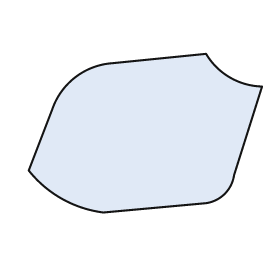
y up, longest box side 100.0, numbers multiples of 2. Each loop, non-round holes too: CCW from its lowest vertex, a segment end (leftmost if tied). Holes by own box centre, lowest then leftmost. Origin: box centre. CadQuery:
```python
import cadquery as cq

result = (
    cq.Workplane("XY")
    .moveTo(-18.0, -34.0)
    .lineTo(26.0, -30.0)
    .threePointArc((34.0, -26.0), (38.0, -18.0))
    .lineTo(50.0, 20.0)
    .threePointArc((36.0, 24.0), (26.0, 34.0))
    .lineTo(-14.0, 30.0)
    .threePointArc((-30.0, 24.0), (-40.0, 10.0))
    .lineTo(-50.0, -16.0)
    .threePointArc((-36.0, -28.0), (-18.0, -34.0))
    .close()
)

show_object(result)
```